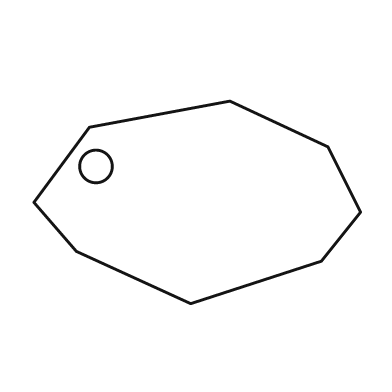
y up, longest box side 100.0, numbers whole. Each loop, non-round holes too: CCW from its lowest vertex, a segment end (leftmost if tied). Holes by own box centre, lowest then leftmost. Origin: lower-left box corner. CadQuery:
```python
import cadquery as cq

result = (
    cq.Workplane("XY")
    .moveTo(48.0, 0.0)
    .lineTo(88.0, 13.0)
    .lineTo(100.0, 28.0)
    .lineTo(90.0, 48.0)
    .lineTo(60.0, 62.0)
    .lineTo(17.0, 54.0)
    .lineTo(0.0, 31.0)
    .lineTo(13.0, 16.0)
    .close()
    .moveTo(19.0, 42.0)
    .circle(5.0)
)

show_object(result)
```